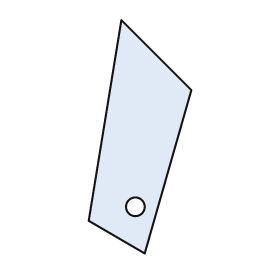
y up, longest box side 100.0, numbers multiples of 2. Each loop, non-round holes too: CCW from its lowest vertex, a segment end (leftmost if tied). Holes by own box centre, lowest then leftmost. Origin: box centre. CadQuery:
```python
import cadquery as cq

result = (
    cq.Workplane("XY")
    .moveTo(2.0, -50.0)
    .lineTo(22.0, 20.0)
    .lineTo(-8.0, 50.0)
    .lineTo(-22.0, -36.0)
    .close()
    .moveTo(-2.0, -30.0)
    .circle(4.0)
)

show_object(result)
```